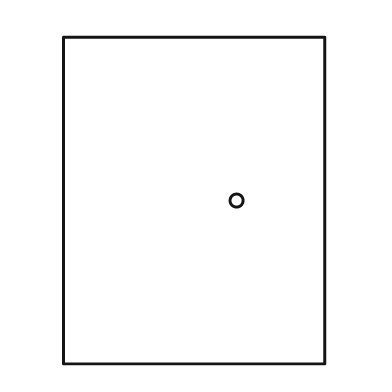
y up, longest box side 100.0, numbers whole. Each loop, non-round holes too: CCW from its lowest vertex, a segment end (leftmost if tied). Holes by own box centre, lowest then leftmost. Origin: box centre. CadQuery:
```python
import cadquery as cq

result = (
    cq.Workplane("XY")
    .moveTo(-40.0, -50.0)
    .lineTo(40.0, -50.0)
    .lineTo(40.0, 50.0)
    .lineTo(-40.0, 50.0)
    .close()
    .moveTo(13.0, 0.0)
    .circle(2.0)
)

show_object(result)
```